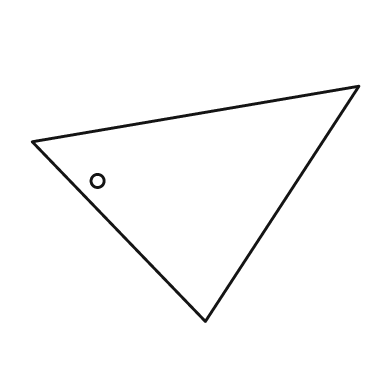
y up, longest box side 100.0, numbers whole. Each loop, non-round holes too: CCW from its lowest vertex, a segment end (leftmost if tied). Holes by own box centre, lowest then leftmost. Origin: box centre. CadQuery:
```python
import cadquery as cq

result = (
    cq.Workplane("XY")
    .moveTo(3.0, -36.0)
    .lineTo(50.0, 36.0)
    .lineTo(-50.0, 19.0)
    .close()
    .moveTo(-30.0, 7.0)
    .circle(2.0)
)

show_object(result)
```